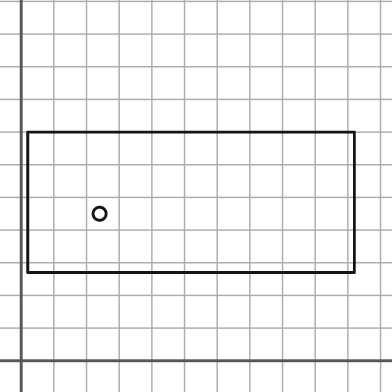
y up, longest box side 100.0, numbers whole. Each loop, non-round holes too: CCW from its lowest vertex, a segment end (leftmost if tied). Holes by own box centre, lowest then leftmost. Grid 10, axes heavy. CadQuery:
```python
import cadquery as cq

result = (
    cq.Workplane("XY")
    .moveTo(2.0, 27.0)
    .lineTo(102.0, 27.0)
    .lineTo(102.0, 70.0)
    .lineTo(2.0, 70.0)
    .close()
    .moveTo(24.0, 45.0)
    .circle(2.0)
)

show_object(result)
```